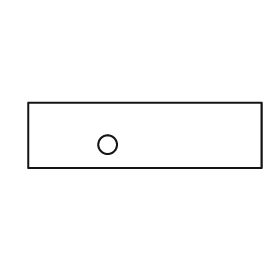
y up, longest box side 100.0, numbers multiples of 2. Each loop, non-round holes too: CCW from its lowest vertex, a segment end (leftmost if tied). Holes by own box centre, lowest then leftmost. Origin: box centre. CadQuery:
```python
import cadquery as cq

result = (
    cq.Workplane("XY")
    .moveTo(-50.0, -14.0)
    .lineTo(50.0, -14.0)
    .lineTo(50.0, 14.0)
    .lineTo(-50.0, 14.0)
    .close()
    .moveTo(-16.0, -4.0)
    .circle(4.0)
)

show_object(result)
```